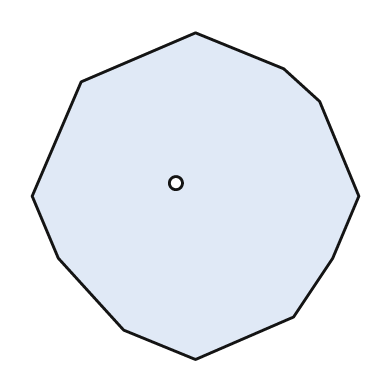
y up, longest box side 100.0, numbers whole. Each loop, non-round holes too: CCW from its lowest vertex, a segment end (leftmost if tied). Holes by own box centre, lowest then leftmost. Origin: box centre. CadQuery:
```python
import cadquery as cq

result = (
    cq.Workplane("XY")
    .moveTo(0.0, -50.0)
    .lineTo(30.0, -37.0)
    .lineTo(42.0, -19.0)
    .lineTo(50.0, 0.0)
    .lineTo(38.0, 29.0)
    .lineTo(27.0, 39.0)
    .lineTo(0.0, 50.0)
    .lineTo(-35.0, 35.0)
    .lineTo(-50.0, 0.0)
    .lineTo(-42.0, -19.0)
    .lineTo(-22.0, -41.0)
    .close()
    .moveTo(-6.0, 4.0)
    .circle(2.0)
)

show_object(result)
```